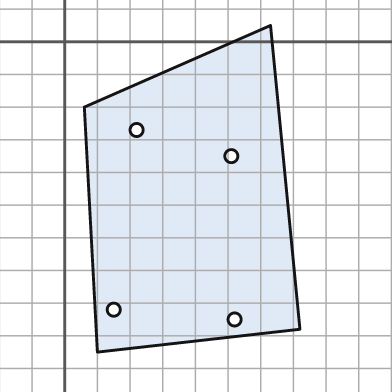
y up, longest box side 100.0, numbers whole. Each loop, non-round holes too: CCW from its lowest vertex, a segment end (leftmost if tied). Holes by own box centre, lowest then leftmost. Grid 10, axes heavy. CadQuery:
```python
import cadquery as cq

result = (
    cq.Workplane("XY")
    .moveTo(10.0, -95.0)
    .lineTo(72.0, -88.0)
    .lineTo(63.0, 5.0)
    .lineTo(6.0, -20.0)
    .close()
    .moveTo(52.0, -85.0)
    .circle(2.0)
    .moveTo(15.0, -82.0)
    .circle(2.0)
    .moveTo(51.0, -35.0)
    .circle(2.0)
    .moveTo(22.0, -27.0)
    .circle(2.0)
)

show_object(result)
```